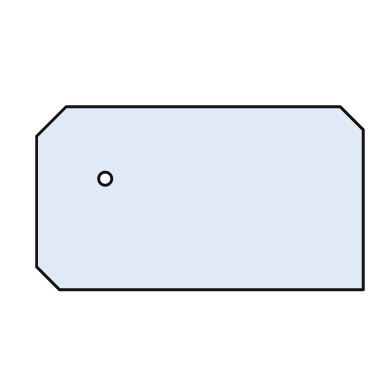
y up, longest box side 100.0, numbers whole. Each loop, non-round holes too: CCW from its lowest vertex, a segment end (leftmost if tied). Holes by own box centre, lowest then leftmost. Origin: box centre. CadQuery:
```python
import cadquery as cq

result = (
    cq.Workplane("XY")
    .moveTo(-43.0, -28.0)
    .lineTo(50.0, -28.0)
    .lineTo(50.0, 21.0)
    .lineTo(43.0, 28.0)
    .lineTo(-41.0, 28.0)
    .lineTo(-50.0, 19.0)
    .lineTo(-50.0, -21.0)
    .close()
    .moveTo(-29.0, 6.0)
    .circle(2.0)
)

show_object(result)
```